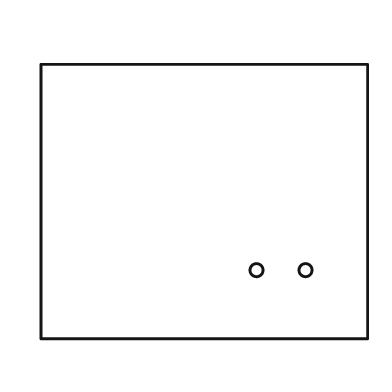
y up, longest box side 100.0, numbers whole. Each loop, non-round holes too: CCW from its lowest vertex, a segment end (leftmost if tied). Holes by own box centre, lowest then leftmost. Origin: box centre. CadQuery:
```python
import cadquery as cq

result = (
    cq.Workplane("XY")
    .moveTo(-50.0, -42.0)
    .lineTo(50.0, -42.0)
    .lineTo(50.0, 42.0)
    .lineTo(-50.0, 42.0)
    .close()
    .moveTo(16.0, -21.0)
    .circle(2.0)
    .moveTo(31.0, -21.0)
    .circle(2.0)
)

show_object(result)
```